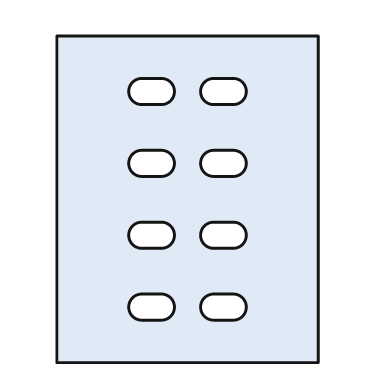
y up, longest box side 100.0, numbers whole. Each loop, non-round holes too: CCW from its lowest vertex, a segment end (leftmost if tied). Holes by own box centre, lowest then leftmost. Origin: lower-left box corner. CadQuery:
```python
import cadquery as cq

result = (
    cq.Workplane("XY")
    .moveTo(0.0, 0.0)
    .lineTo(80.0, 0.0)
    .lineTo(80.0, 100.0)
    .lineTo(0.0, 100.0)
    .close()
    .moveTo(26.0, 13.0)
    .lineTo(32.0, 13.0)
    .threePointArc((36.0, 17.0), (32.0, 21.0))
    .lineTo(26.0, 21.0)
    .threePointArc((22.0, 17.0), (26.0, 13.0))
    .close()
    .moveTo(48.0, 13.0)
    .lineTo(54.0, 13.0)
    .threePointArc((58.0, 17.0), (54.0, 21.0))
    .lineTo(48.0, 21.0)
    .threePointArc((44.0, 17.0), (48.0, 13.0))
    .close()
    .moveTo(26.0, 35.0)
    .lineTo(32.0, 35.0)
    .threePointArc((36.0, 39.0), (32.0, 43.0))
    .lineTo(26.0, 43.0)
    .threePointArc((22.0, 39.0), (26.0, 35.0))
    .close()
    .moveTo(48.0, 35.0)
    .lineTo(54.0, 35.0)
    .threePointArc((58.0, 39.0), (54.0, 43.0))
    .lineTo(48.0, 43.0)
    .threePointArc((44.0, 39.0), (48.0, 35.0))
    .close()
    .moveTo(26.0, 57.0)
    .lineTo(32.0, 57.0)
    .threePointArc((36.0, 61.0), (32.0, 65.0))
    .lineTo(26.0, 65.0)
    .threePointArc((22.0, 61.0), (26.0, 57.0))
    .close()
    .moveTo(48.0, 57.0)
    .lineTo(54.0, 57.0)
    .threePointArc((58.0, 61.0), (54.0, 65.0))
    .lineTo(48.0, 65.0)
    .threePointArc((44.0, 61.0), (48.0, 57.0))
    .close()
    .moveTo(26.0, 79.0)
    .lineTo(32.0, 79.0)
    .threePointArc((36.0, 83.0), (32.0, 87.0))
    .lineTo(26.0, 87.0)
    .threePointArc((22.0, 83.0), (26.0, 79.0))
    .close()
    .moveTo(48.0, 79.0)
    .lineTo(54.0, 79.0)
    .threePointArc((58.0, 83.0), (54.0, 87.0))
    .lineTo(48.0, 87.0)
    .threePointArc((44.0, 83.0), (48.0, 79.0))
    .close()
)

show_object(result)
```